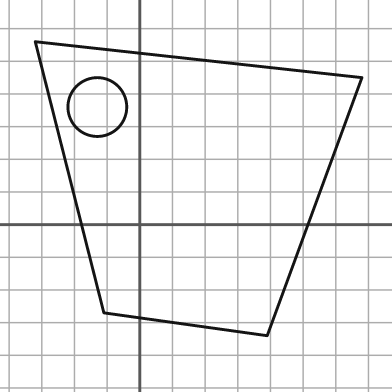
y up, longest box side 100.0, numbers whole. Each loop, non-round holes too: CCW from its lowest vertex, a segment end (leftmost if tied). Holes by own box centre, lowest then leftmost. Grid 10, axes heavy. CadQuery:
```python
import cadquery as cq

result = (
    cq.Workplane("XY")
    .moveTo(39.0, -34.0)
    .lineTo(68.0, 45.0)
    .lineTo(-32.0, 56.0)
    .lineTo(-11.0, -27.0)
    .close()
    .moveTo(-13.0, 36.0)
    .circle(9.0)
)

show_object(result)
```